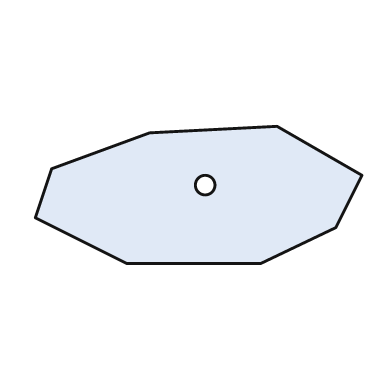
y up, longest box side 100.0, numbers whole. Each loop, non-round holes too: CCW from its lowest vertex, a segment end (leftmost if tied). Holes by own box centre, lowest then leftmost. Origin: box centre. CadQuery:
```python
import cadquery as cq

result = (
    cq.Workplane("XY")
    .moveTo(-22.0, -21.0)
    .lineTo(19.0, -21.0)
    .lineTo(42.0, -10.0)
    .lineTo(50.0, 6.0)
    .lineTo(24.0, 21.0)
    .lineTo(-15.0, 19.0)
    .lineTo(-45.0, 8.0)
    .lineTo(-50.0, -7.0)
    .close()
    .moveTo(2.0, 3.0)
    .circle(3.0)
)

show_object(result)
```